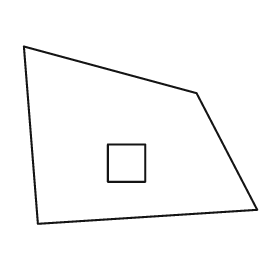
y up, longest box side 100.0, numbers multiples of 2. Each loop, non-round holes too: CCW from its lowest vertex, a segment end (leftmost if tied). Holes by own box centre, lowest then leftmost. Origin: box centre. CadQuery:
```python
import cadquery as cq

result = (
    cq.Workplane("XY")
    .moveTo(-44.0, -38.0)
    .lineTo(50.0, -32.0)
    .lineTo(24.0, 18.0)
    .lineTo(-50.0, 38.0)
    .close()
    .moveTo(-14.0, -20.0)
    .lineTo(2.0, -20.0)
    .lineTo(2.0, -4.0)
    .lineTo(-14.0, -4.0)
    .close()
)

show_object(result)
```